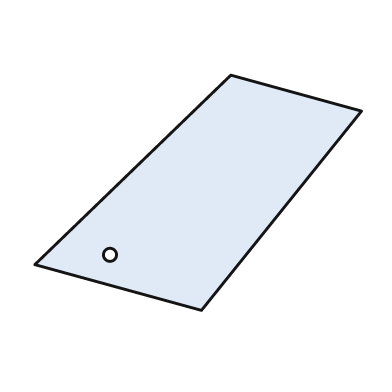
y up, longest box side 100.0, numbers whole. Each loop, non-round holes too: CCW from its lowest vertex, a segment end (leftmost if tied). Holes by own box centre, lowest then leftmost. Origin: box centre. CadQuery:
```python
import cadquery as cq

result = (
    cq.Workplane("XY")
    .moveTo(1.0, -36.0)
    .lineTo(50.0, 25.0)
    .lineTo(10.0, 36.0)
    .lineTo(-50.0, -22.0)
    .close()
    .moveTo(-27.0, -19.0)
    .circle(2.0)
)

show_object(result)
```